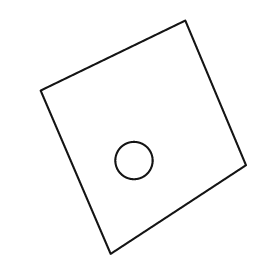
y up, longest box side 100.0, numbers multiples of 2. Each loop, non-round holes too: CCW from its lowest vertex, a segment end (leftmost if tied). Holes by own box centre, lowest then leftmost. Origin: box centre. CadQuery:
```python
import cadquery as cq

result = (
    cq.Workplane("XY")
    .moveTo(-14.0, -50.0)
    .lineTo(44.0, -12.0)
    .lineTo(18.0, 50.0)
    .lineTo(-44.0, 20.0)
    .close()
    .moveTo(-4.0, -10.0)
    .circle(8.0)
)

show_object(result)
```